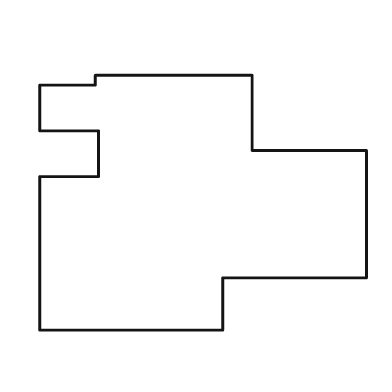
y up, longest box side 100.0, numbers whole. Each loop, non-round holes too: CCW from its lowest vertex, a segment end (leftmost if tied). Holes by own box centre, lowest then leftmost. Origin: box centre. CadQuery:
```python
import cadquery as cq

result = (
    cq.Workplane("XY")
    .moveTo(-50.0, -39.0)
    .lineTo(6.0, -39.0)
    .lineTo(6.0, -23.0)
    .lineTo(50.0, -23.0)
    .lineTo(50.0, 16.0)
    .lineTo(15.0, 16.0)
    .lineTo(15.0, 39.0)
    .lineTo(-33.0, 39.0)
    .lineTo(-33.0, 36.0)
    .lineTo(-50.0, 36.0)
    .lineTo(-50.0, 22.0)
    .lineTo(-32.0, 22.0)
    .lineTo(-32.0, 8.0)
    .lineTo(-50.0, 8.0)
    .close()
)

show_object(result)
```